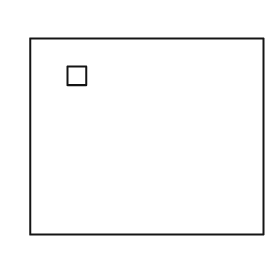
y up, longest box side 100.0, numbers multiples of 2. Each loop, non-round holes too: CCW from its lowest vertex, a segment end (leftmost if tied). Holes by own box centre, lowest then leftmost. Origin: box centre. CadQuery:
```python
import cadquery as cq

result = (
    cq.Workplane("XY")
    .moveTo(-50.0, -42.0)
    .lineTo(50.0, -42.0)
    .lineTo(50.0, 42.0)
    .lineTo(-50.0, 42.0)
    .close()
    .moveTo(-34.0, 22.0)
    .lineTo(-26.0, 22.0)
    .lineTo(-26.0, 30.0)
    .lineTo(-34.0, 30.0)
    .close()
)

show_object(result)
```